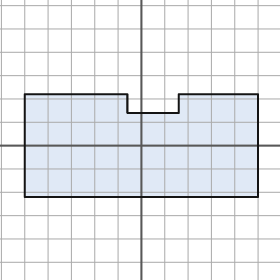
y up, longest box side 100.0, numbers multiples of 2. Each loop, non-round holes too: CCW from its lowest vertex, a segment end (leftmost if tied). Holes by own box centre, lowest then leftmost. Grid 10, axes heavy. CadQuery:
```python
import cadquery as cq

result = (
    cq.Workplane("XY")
    .moveTo(-50.0, -22.0)
    .lineTo(50.0, -22.0)
    .lineTo(50.0, 22.0)
    .lineTo(16.0, 22.0)
    .lineTo(16.0, 14.0)
    .lineTo(-6.0, 14.0)
    .lineTo(-6.0, 22.0)
    .lineTo(-50.0, 22.0)
    .close()
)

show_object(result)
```